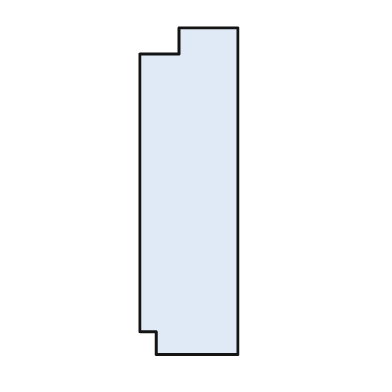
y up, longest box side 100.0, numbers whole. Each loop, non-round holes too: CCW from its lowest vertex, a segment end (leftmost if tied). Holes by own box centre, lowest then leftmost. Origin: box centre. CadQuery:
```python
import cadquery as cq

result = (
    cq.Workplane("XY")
    .moveTo(-10.0, -50.0)
    .lineTo(15.0, -50.0)
    .lineTo(15.0, 50.0)
    .lineTo(-3.0, 50.0)
    .lineTo(-3.0, 42.0)
    .lineTo(-15.0, 42.0)
    .lineTo(-15.0, -43.0)
    .lineTo(-10.0, -43.0)
    .close()
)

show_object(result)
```